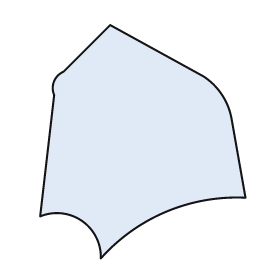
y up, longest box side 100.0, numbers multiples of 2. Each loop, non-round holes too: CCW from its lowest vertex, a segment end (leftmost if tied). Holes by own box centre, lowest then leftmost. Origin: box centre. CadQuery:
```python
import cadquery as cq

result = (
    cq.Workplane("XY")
    .moveTo(-18.0, -50.0)
    .threePointArc((10.0, -30.0), (44.0, -24.0))
    .lineTo(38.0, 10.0)
    .threePointArc((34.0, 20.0), (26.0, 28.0))
    .lineTo(-14.0, 50.0)
    .lineTo(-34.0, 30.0)
    .threePointArc((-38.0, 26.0), (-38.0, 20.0))
    .lineTo(-44.0, -32.0)
    .threePointArc((-26.0, -34.0), (-18.0, -50.0))
    .close()
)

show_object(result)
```